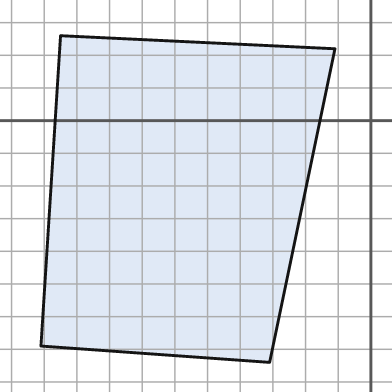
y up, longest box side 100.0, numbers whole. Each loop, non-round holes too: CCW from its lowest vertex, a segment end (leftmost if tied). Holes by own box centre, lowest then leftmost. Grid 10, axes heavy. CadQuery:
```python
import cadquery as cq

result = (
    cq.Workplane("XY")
    .moveTo(-31.0, -74.0)
    .lineTo(-11.0, 22.0)
    .lineTo(-95.0, 26.0)
    .lineTo(-101.0, -69.0)
    .close()
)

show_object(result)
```